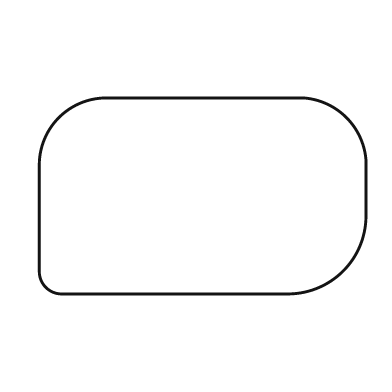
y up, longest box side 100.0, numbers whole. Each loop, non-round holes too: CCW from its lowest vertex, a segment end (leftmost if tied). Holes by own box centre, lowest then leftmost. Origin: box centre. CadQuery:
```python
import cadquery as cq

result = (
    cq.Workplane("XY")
    .moveTo(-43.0, -30.0)
    .lineTo(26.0, -30.0)
    .threePointArc((43.0, -23.0), (50.0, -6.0))
    .lineTo(50.0, 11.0)
    .threePointArc((44.0, 24.0), (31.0, 30.0))
    .lineTo(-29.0, 30.0)
    .threePointArc((-44.0, 24.0), (-50.0, 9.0))
    .lineTo(-50.0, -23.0)
    .threePointArc((-48.0, -28.0), (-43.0, -30.0))
    .close()
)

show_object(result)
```